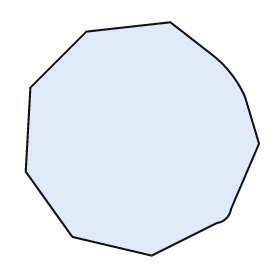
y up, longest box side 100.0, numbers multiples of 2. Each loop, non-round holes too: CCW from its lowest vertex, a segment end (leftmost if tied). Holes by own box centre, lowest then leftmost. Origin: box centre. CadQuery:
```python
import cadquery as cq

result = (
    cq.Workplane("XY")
    .moveTo(4.0, -50.0)
    .lineTo(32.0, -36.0)
    .threePointArc((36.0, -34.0), (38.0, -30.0))
    .lineTo(50.0, -2.0)
    .lineTo(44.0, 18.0)
    .threePointArc((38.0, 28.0), (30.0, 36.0))
    .lineTo(12.0, 50.0)
    .lineTo(-24.0, 46.0)
    .lineTo(-48.0, 22.0)
    .lineTo(-50.0, -14.0)
    .lineTo(-30.0, -42.0)
    .close()
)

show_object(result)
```